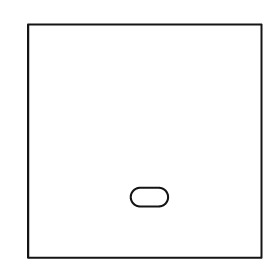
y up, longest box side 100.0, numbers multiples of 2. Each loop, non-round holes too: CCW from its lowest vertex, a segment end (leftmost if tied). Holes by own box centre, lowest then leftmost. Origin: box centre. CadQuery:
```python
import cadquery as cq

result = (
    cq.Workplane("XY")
    .moveTo(-50.0, -50.0)
    .lineTo(50.0, -50.0)
    .lineTo(50.0, 50.0)
    .lineTo(-50.0, 50.0)
    .close()
    .moveTo(-2.0, -28.0)
    .lineTo(6.0, -28.0)
    .threePointArc((10.0, -24.0), (6.0, -20.0))
    .lineTo(-2.0, -20.0)
    .threePointArc((-6.0, -24.0), (-2.0, -28.0))
    .close()
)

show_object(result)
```